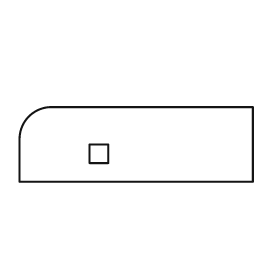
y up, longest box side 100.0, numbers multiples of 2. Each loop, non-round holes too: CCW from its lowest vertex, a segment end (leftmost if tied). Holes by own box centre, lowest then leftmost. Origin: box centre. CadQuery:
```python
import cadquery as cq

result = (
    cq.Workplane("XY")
    .moveTo(-50.0, -16.0)
    .lineTo(50.0, -16.0)
    .lineTo(50.0, 16.0)
    .lineTo(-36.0, 16.0)
    .threePointArc((-46.0, 12.0), (-50.0, 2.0))
    .close()
    .moveTo(-20.0, -8.0)
    .lineTo(-12.0, -8.0)
    .lineTo(-12.0, 0.0)
    .lineTo(-20.0, 0.0)
    .close()
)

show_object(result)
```